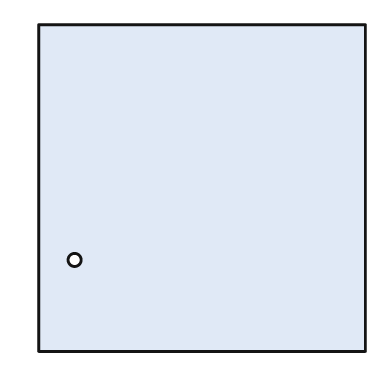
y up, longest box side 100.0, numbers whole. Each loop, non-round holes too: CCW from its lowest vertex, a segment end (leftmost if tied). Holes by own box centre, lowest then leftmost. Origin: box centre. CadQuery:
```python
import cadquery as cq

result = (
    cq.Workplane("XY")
    .moveTo(-50.0, -50.0)
    .lineTo(50.0, -50.0)
    .lineTo(50.0, 50.0)
    .lineTo(-50.0, 50.0)
    .close()
    .moveTo(-39.0, -22.0)
    .circle(2.0)
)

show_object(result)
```